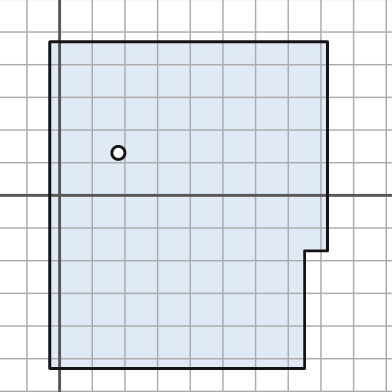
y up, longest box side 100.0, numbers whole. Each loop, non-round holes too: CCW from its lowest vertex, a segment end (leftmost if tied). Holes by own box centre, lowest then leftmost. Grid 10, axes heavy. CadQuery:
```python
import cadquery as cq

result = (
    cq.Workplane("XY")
    .moveTo(-3.0, -53.0)
    .lineTo(75.0, -53.0)
    .lineTo(75.0, -17.0)
    .lineTo(82.0, -17.0)
    .lineTo(82.0, 47.0)
    .lineTo(-3.0, 47.0)
    .close()
    .moveTo(18.0, 13.0)
    .circle(2.0)
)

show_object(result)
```